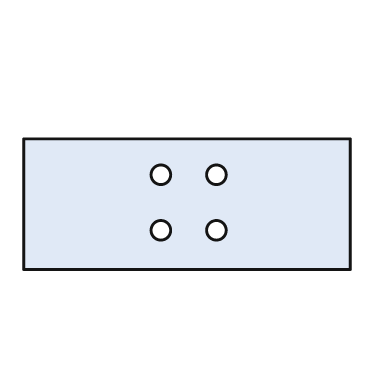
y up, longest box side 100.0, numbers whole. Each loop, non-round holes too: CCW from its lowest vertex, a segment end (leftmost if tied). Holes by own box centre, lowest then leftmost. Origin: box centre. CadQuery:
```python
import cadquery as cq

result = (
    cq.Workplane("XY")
    .moveTo(-50.0, -20.0)
    .lineTo(50.0, -20.0)
    .lineTo(50.0, 20.0)
    .lineTo(-50.0, 20.0)
    .close()
    .moveTo(-8.0, -8.0)
    .circle(3.0)
    .moveTo(9.0, -8.0)
    .circle(3.0)
    .moveTo(-8.0, 9.0)
    .circle(3.0)
    .moveTo(9.0, 9.0)
    .circle(3.0)
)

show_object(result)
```